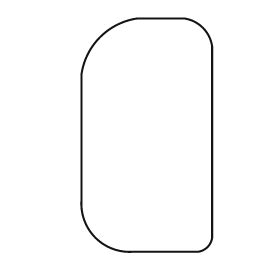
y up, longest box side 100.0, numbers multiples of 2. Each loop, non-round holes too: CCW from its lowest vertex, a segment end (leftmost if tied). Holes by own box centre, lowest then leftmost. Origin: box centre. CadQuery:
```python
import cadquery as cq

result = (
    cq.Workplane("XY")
    .moveTo(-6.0, -50.0)
    .lineTo(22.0, -50.0)
    .threePointArc((26.0, -48.0), (28.0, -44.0))
    .lineTo(28.0, 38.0)
    .threePointArc((24.0, 46.0), (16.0, 50.0))
    .lineTo(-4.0, 50.0)
    .threePointArc((-20.0, 42.0), (-28.0, 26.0))
    .lineTo(-28.0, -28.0)
    .threePointArc((-22.0, -44.0), (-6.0, -50.0))
    .close()
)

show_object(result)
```